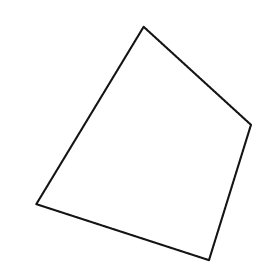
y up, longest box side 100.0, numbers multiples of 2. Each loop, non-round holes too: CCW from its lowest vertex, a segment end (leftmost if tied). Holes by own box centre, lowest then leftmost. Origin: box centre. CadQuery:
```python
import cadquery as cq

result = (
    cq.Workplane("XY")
    .moveTo(28.0, -50.0)
    .lineTo(46.0, 8.0)
    .lineTo(0.0, 50.0)
    .lineTo(-46.0, -26.0)
    .close()
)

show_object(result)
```